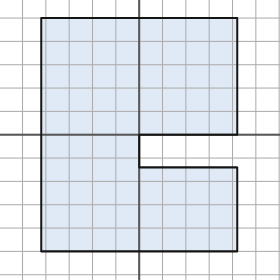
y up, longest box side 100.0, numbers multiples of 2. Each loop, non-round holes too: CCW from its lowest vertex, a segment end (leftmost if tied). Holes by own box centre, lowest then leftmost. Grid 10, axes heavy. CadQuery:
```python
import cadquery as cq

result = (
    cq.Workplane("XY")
    .moveTo(-42.0, -50.0)
    .lineTo(42.0, -50.0)
    .lineTo(42.0, -14.0)
    .lineTo(0.0, -14.0)
    .lineTo(0.0, 0.0)
    .lineTo(42.0, 0.0)
    .lineTo(42.0, 50.0)
    .lineTo(-42.0, 50.0)
    .close()
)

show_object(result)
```